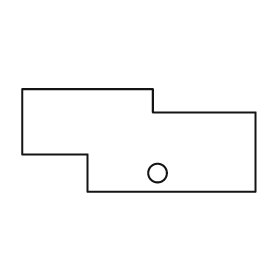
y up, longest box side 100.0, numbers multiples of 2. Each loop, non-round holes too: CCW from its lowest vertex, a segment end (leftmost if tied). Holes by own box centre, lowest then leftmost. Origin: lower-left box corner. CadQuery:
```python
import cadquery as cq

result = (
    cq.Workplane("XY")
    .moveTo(28.0, 0.0)
    .lineTo(100.0, 0.0)
    .lineTo(100.0, 34.0)
    .lineTo(56.0, 34.0)
    .lineTo(56.0, 44.0)
    .lineTo(0.0, 44.0)
    .lineTo(0.0, 16.0)
    .lineTo(28.0, 16.0)
    .close()
    .moveTo(58.0, 8.0)
    .circle(4.0)
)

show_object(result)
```